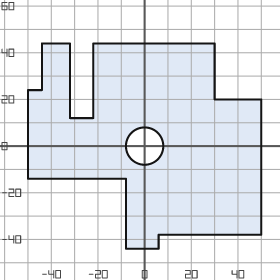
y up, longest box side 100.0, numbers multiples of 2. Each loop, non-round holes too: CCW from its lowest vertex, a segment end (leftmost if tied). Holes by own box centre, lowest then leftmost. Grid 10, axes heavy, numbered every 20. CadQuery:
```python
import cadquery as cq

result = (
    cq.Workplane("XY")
    .moveTo(-8.0, -44.0)
    .lineTo(6.0, -44.0)
    .lineTo(6.0, -38.0)
    .lineTo(50.0, -38.0)
    .lineTo(50.0, 20.0)
    .lineTo(30.0, 20.0)
    .lineTo(30.0, 44.0)
    .lineTo(-22.0, 44.0)
    .lineTo(-22.0, 12.0)
    .lineTo(-32.0, 12.0)
    .lineTo(-32.0, 44.0)
    .lineTo(-44.0, 44.0)
    .lineTo(-44.0, 24.0)
    .lineTo(-50.0, 24.0)
    .lineTo(-50.0, -14.0)
    .lineTo(-8.0, -14.0)
    .close()
    .moveTo(0.0, 0.0)
    .circle(8.0)
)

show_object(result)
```